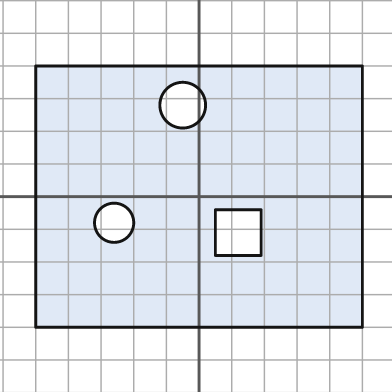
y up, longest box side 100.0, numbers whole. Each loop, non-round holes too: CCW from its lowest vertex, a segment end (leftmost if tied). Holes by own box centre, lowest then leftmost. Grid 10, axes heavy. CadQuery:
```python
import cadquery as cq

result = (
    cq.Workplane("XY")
    .moveTo(-50.0, -40.0)
    .lineTo(50.0, -40.0)
    .lineTo(50.0, 40.0)
    .lineTo(-50.0, 40.0)
    .close()
    .moveTo(5.0, -18.0)
    .lineTo(19.0, -18.0)
    .lineTo(19.0, -4.0)
    .lineTo(5.0, -4.0)
    .close()
    .moveTo(-26.0, -8.0)
    .circle(6.0)
    .moveTo(-5.0, 28.0)
    .circle(7.0)
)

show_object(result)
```